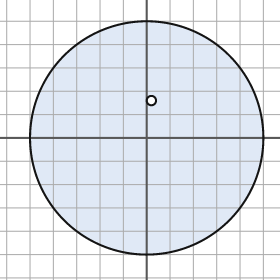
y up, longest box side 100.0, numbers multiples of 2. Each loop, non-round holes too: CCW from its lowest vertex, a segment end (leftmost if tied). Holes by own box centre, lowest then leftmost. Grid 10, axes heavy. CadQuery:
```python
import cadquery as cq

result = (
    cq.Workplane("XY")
    .moveTo(0.0, 0.0)
    .circle(50.0)
    .moveTo(2.0, 16.0)
    .circle(2.0)
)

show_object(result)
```